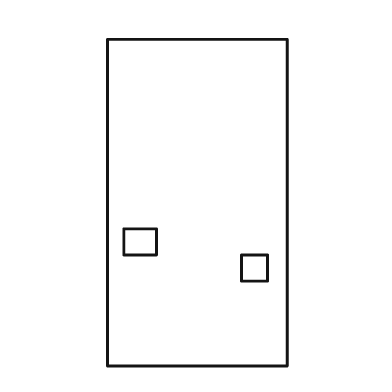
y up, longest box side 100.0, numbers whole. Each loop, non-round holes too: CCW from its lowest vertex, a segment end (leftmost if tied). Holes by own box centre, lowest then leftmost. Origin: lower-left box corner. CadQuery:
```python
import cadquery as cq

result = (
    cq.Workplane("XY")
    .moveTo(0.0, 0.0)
    .lineTo(55.0, 0.0)
    .lineTo(55.0, 100.0)
    .lineTo(0.0, 100.0)
    .close()
    .moveTo(41.0, 26.0)
    .lineTo(49.0, 26.0)
    .lineTo(49.0, 34.0)
    .lineTo(41.0, 34.0)
    .close()
    .moveTo(5.0, 34.0)
    .lineTo(15.0, 34.0)
    .lineTo(15.0, 42.0)
    .lineTo(5.0, 42.0)
    .close()
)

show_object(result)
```